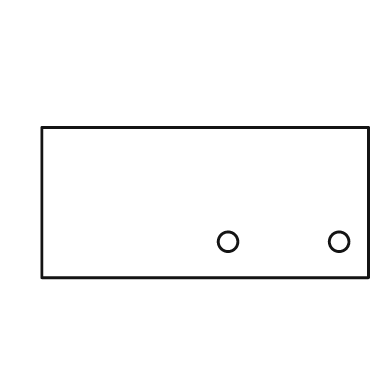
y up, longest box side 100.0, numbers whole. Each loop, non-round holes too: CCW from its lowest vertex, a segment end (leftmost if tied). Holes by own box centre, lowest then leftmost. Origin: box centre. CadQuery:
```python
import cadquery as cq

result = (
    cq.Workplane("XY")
    .moveTo(-50.0, -23.0)
    .lineTo(50.0, -23.0)
    .lineTo(50.0, 23.0)
    .lineTo(-50.0, 23.0)
    .close()
    .moveTo(7.0, -12.0)
    .circle(3.0)
    .moveTo(41.0, -12.0)
    .circle(3.0)
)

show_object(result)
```